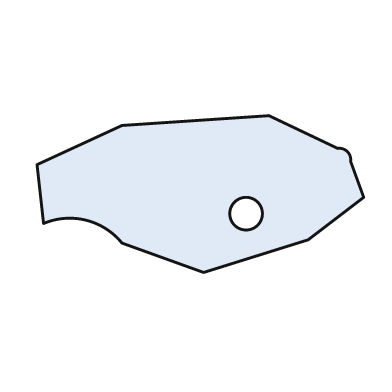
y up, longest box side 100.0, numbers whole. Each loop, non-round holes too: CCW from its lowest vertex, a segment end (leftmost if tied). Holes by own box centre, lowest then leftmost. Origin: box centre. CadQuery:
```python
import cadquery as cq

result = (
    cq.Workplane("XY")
    .moveTo(1.0, -24.0)
    .lineTo(33.0, -14.0)
    .lineTo(50.0, -1.0)
    .lineTo(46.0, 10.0)
    .threePointArc((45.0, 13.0), (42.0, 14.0))
    .lineTo(21.0, 24.0)
    .lineTo(-24.0, 21.0)
    .lineTo(-50.0, 9.0)
    .lineTo(-48.0, -9.0)
    .threePointArc((-35.0, -8.0), (-24.0, -15.0))
    .close()
    .moveTo(14.0, -6.0)
    .circle(5.0)
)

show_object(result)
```